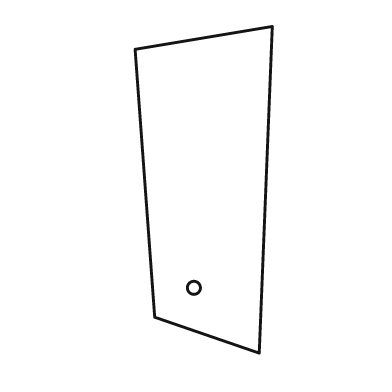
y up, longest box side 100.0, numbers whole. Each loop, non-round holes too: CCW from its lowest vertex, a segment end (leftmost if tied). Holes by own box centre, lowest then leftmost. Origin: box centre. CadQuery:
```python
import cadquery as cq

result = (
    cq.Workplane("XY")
    .moveTo(17.0, -50.0)
    .lineTo(21.0, 50.0)
    .lineTo(-21.0, 43.0)
    .lineTo(-15.0, -39.0)
    .close()
    .moveTo(-3.0, -30.0)
    .circle(2.0)
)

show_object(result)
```